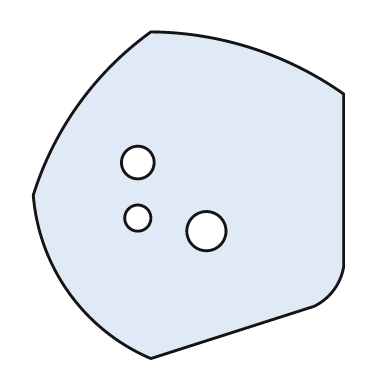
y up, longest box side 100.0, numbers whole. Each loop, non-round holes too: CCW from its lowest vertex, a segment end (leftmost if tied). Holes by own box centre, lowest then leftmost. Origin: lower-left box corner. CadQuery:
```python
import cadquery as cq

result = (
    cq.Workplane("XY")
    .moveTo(36.0, 0.0)
    .lineTo(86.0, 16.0)
    .threePointArc((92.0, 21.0), (95.0, 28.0))
    .lineTo(95.0, 81.0)
    .threePointArc((67.0, 95.0), (36.0, 100.0))
    .threePointArc((14.0, 78.0), (0.0, 50.0))
    .threePointArc((11.0, 20.0), (36.0, 0.0))
    .close()
    .moveTo(53.0, 39.0)
    .circle(6.0)
    .moveTo(32.0, 43.0)
    .circle(4.0)
    .moveTo(32.0, 60.0)
    .circle(5.0)
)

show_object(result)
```